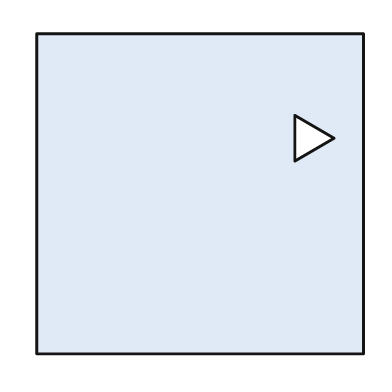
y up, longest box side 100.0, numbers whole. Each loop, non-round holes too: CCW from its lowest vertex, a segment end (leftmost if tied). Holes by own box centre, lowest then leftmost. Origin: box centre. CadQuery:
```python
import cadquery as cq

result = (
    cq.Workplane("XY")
    .moveTo(-50.0, -49.0)
    .lineTo(50.0, -49.0)
    .lineTo(50.0, 49.0)
    .lineTo(-50.0, 49.0)
    .close()
    .moveTo(29.0, 10.0)
    .lineTo(41.0, 17.0)
    .lineTo(29.0, 24.0)
    .close()
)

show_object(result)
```